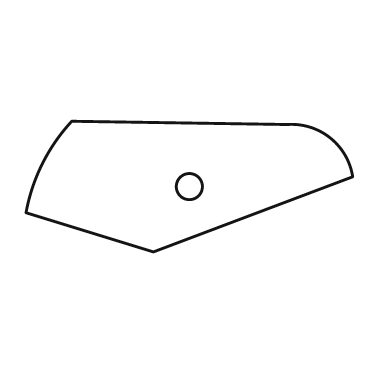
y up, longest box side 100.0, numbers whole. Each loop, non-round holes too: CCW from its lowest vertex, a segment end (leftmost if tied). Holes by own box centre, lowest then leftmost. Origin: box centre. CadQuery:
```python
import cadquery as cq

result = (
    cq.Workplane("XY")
    .moveTo(-11.0, -20.0)
    .lineTo(50.0, 3.0)
    .threePointArc((43.0, 15.0), (30.0, 19.0))
    .lineTo(-36.0, 20.0)
    .threePointArc((-45.0, 7.0), (-50.0, -8.0))
    .close()
    .moveTo(0.0, 0.0)
    .circle(4.0)
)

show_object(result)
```